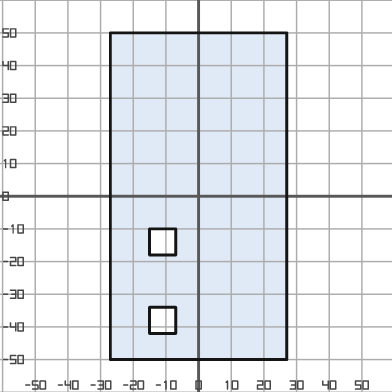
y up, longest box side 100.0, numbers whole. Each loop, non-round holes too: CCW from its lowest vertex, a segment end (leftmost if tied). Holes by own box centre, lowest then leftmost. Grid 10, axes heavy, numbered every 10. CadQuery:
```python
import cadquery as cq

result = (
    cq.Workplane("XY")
    .moveTo(-27.0, -50.0)
    .lineTo(27.0, -50.0)
    .lineTo(27.0, 50.0)
    .lineTo(-27.0, 50.0)
    .close()
    .moveTo(-15.0, -42.0)
    .lineTo(-7.0, -42.0)
    .lineTo(-7.0, -34.0)
    .lineTo(-15.0, -34.0)
    .close()
    .moveTo(-15.0, -18.0)
    .lineTo(-7.0, -18.0)
    .lineTo(-7.0, -10.0)
    .lineTo(-15.0, -10.0)
    .close()
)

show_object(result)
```